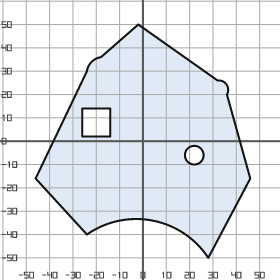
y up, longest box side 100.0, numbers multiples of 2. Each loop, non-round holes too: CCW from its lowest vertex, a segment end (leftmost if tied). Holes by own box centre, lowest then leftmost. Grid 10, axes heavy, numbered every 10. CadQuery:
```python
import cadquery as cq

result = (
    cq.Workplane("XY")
    .moveTo(28.0, -50.0)
    .lineTo(46.0, -16.0)
    .lineTo(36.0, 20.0)
    .threePointArc((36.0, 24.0), (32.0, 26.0))
    .lineTo(-2.0, 50.0)
    .lineTo(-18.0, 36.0)
    .threePointArc((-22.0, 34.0), (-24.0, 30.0))
    .lineTo(-46.0, -16.0)
    .lineTo(-24.0, -40.0)
    .threePointArc((4.0, -34.0), (28.0, -50.0))
    .close()
    .moveTo(22.0, -6.0)
    .circle(4.0)
    .moveTo(-26.0, 2.0)
    .lineTo(-14.0, 2.0)
    .lineTo(-14.0, 14.0)
    .lineTo(-26.0, 14.0)
    .close()
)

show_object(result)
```